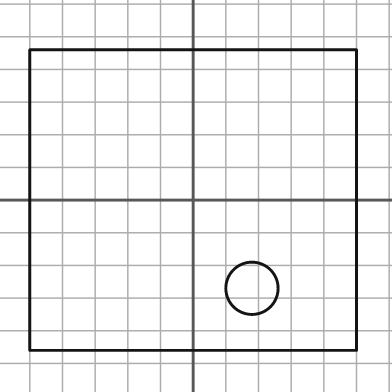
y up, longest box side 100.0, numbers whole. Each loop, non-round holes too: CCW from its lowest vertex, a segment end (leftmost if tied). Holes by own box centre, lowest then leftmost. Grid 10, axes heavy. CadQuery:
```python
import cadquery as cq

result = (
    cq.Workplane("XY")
    .moveTo(-50.0, -46.0)
    .lineTo(50.0, -46.0)
    .lineTo(50.0, 46.0)
    .lineTo(-50.0, 46.0)
    .close()
    .moveTo(18.0, -27.0)
    .circle(8.0)
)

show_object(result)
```